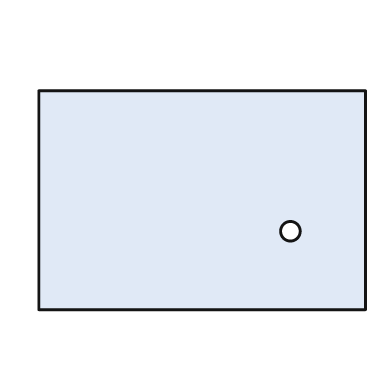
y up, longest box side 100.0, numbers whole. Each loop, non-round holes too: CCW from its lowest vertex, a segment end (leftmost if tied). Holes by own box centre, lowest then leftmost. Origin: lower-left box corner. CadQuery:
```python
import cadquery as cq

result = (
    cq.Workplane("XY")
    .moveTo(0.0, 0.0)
    .lineTo(100.0, 0.0)
    .lineTo(100.0, 67.0)
    .lineTo(0.0, 67.0)
    .close()
    .moveTo(77.0, 24.0)
    .circle(3.0)
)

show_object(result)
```